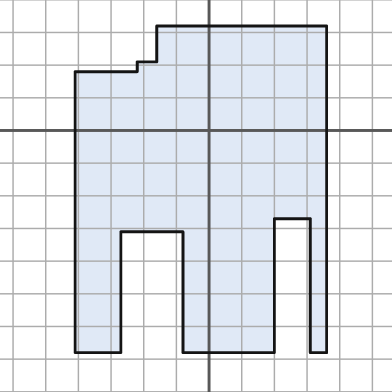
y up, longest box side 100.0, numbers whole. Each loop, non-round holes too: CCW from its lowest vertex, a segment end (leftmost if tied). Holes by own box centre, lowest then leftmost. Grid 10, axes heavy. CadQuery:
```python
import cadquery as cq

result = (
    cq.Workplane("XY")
    .moveTo(-41.0, -68.0)
    .lineTo(-27.0, -68.0)
    .lineTo(-27.0, -31.0)
    .lineTo(-8.0, -31.0)
    .lineTo(-8.0, -68.0)
    .lineTo(20.0, -68.0)
    .lineTo(20.0, -27.0)
    .lineTo(31.0, -27.0)
    .lineTo(31.0, -68.0)
    .lineTo(36.0, -68.0)
    .lineTo(36.0, 32.0)
    .lineTo(-16.0, 32.0)
    .lineTo(-16.0, 21.0)
    .lineTo(-22.0, 21.0)
    .lineTo(-22.0, 18.0)
    .lineTo(-41.0, 18.0)
    .close()
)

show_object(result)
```